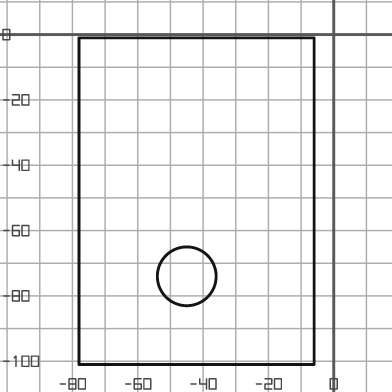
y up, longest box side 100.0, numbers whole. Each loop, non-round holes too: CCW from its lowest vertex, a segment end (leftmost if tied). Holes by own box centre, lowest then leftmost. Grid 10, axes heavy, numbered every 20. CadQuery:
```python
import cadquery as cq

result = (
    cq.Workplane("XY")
    .moveTo(-78.0, -101.0)
    .lineTo(-6.0, -101.0)
    .lineTo(-6.0, -1.0)
    .lineTo(-78.0, -1.0)
    .close()
    .moveTo(-45.0, -74.0)
    .circle(9.0)
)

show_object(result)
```